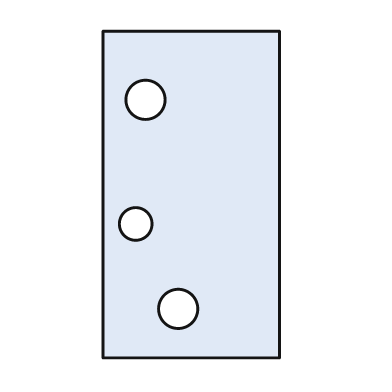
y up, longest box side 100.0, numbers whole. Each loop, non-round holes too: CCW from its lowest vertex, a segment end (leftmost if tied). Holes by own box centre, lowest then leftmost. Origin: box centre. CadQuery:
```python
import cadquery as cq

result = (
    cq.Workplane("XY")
    .moveTo(-27.0, -50.0)
    .lineTo(27.0, -50.0)
    .lineTo(27.0, 50.0)
    .lineTo(-27.0, 50.0)
    .close()
    .moveTo(-4.0, -35.0)
    .circle(6.0)
    .moveTo(-17.0, -9.0)
    .circle(5.0)
    .moveTo(-14.0, 29.0)
    .circle(6.0)
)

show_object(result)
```